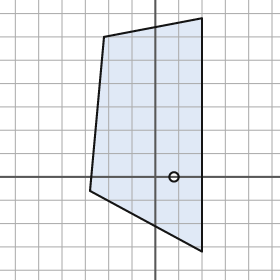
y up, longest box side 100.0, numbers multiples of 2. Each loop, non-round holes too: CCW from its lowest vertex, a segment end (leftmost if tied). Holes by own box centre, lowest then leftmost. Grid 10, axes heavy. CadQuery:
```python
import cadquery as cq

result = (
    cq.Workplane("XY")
    .moveTo(20.0, -32.0)
    .lineTo(20.0, 68.0)
    .lineTo(-22.0, 60.0)
    .lineTo(-28.0, -6.0)
    .close()
    .moveTo(8.0, 0.0)
    .circle(2.0)
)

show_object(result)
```